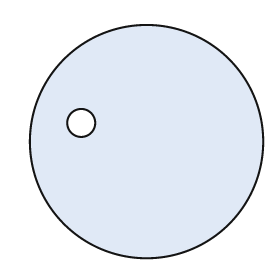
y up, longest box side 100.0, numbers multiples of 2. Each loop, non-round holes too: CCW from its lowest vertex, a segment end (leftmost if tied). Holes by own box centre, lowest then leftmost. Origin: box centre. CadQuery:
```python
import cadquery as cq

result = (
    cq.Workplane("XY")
    .moveTo(0.0, 0.0)
    .circle(50.0)
    .moveTo(-28.0, 8.0)
    .circle(6.0)
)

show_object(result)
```